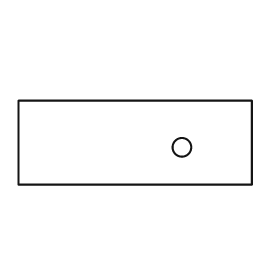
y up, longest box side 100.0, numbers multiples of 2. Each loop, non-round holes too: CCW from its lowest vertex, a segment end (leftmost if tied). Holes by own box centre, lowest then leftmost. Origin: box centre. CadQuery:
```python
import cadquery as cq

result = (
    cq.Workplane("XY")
    .moveTo(-50.0, -18.0)
    .lineTo(50.0, -18.0)
    .lineTo(50.0, 18.0)
    .lineTo(-50.0, 18.0)
    .close()
    .moveTo(20.0, -2.0)
    .circle(4.0)
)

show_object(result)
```